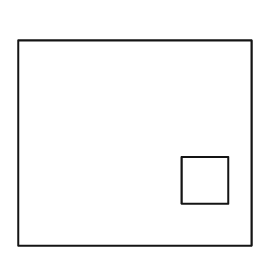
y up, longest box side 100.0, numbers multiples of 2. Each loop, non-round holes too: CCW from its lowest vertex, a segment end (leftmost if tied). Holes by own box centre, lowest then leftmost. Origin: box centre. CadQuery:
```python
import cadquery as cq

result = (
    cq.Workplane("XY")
    .moveTo(-50.0, -44.0)
    .lineTo(50.0, -44.0)
    .lineTo(50.0, 44.0)
    .lineTo(-50.0, 44.0)
    .close()
    .moveTo(20.0, -26.0)
    .lineTo(40.0, -26.0)
    .lineTo(40.0, -6.0)
    .lineTo(20.0, -6.0)
    .close()
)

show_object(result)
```